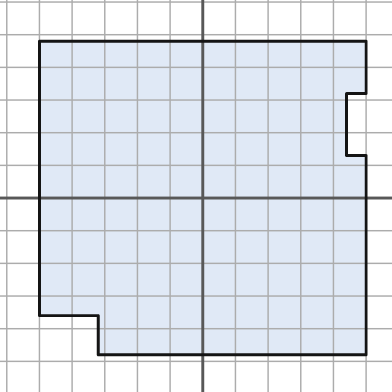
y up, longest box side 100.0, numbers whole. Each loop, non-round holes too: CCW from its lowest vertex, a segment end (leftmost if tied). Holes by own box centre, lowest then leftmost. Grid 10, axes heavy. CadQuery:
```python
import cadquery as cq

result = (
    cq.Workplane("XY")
    .moveTo(-32.0, -48.0)
    .lineTo(50.0, -48.0)
    .lineTo(50.0, 13.0)
    .lineTo(44.0, 13.0)
    .lineTo(44.0, 32.0)
    .lineTo(50.0, 32.0)
    .lineTo(50.0, 48.0)
    .lineTo(-50.0, 48.0)
    .lineTo(-50.0, -36.0)
    .lineTo(-32.0, -36.0)
    .close()
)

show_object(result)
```